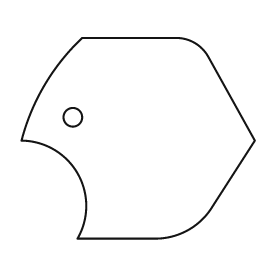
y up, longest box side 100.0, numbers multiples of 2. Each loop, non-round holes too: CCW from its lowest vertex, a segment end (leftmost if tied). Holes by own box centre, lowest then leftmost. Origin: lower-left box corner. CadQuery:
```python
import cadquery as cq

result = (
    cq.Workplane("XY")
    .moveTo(24.0, 0.0)
    .lineTo(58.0, 0.0)
    .threePointArc((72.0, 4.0), (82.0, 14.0))
    .lineTo(100.0, 42.0)
    .lineTo(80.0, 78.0)
    .threePointArc((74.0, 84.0), (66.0, 86.0))
    .lineTo(26.0, 86.0)
    .threePointArc((10.0, 66.0), (0.0, 42.0))
    .threePointArc((24.0, 28.0), (24.0, 0.0))
    .close()
    .moveTo(22.0, 52.0)
    .circle(4.0)
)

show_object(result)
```